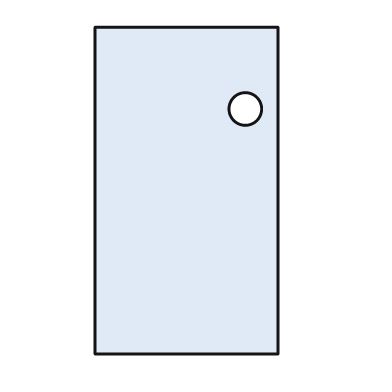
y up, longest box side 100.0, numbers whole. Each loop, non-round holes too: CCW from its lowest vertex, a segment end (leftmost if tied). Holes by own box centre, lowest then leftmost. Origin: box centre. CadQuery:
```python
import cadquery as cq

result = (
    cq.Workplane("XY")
    .moveTo(-28.0, -50.0)
    .lineTo(28.0, -50.0)
    .lineTo(28.0, 50.0)
    .lineTo(-28.0, 50.0)
    .close()
    .moveTo(18.0, 25.0)
    .circle(5.0)
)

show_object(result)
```